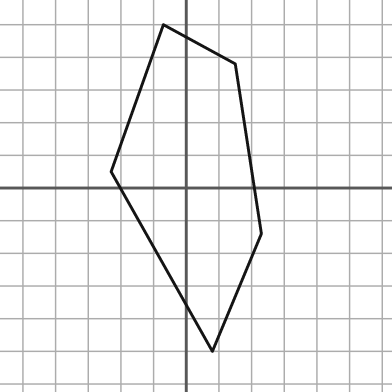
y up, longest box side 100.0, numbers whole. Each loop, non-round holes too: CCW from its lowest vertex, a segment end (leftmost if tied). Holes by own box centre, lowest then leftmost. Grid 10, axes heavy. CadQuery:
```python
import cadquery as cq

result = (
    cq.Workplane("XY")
    .moveTo(8.0, -50.0)
    .lineTo(23.0, -14.0)
    .lineTo(15.0, 38.0)
    .lineTo(-7.0, 50.0)
    .lineTo(-23.0, 5.0)
    .close()
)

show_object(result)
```